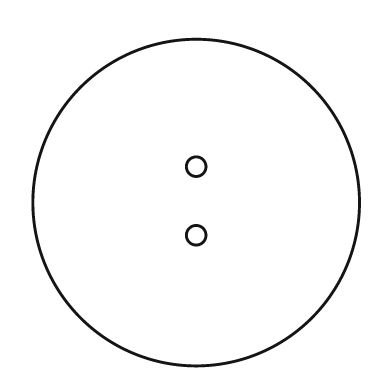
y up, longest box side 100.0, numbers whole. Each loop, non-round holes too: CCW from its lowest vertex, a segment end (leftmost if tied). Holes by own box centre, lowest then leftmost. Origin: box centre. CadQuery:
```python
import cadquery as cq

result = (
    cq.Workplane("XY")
    .moveTo(0.0, 0.0)
    .circle(50.0)
    .moveTo(0.0, -10.0)
    .circle(3.0)
    .moveTo(0.0, 11.0)
    .circle(3.0)
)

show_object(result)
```